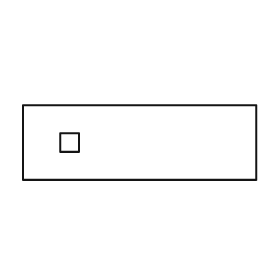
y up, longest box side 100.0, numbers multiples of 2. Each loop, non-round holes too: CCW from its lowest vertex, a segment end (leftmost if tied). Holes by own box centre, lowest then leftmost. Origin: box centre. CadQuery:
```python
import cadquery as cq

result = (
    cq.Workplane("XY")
    .moveTo(-50.0, -16.0)
    .lineTo(50.0, -16.0)
    .lineTo(50.0, 16.0)
    .lineTo(-50.0, 16.0)
    .close()
    .moveTo(-34.0, -4.0)
    .lineTo(-26.0, -4.0)
    .lineTo(-26.0, 4.0)
    .lineTo(-34.0, 4.0)
    .close()
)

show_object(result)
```